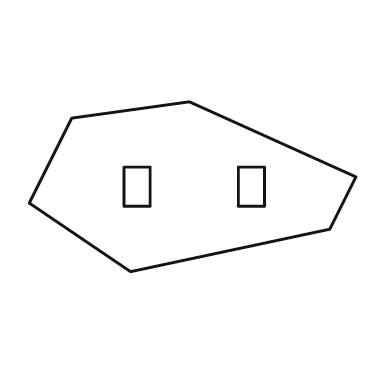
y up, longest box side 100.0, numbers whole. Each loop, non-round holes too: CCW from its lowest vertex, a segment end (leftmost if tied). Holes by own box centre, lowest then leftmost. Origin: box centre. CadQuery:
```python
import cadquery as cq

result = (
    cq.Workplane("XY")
    .moveTo(-19.0, -26.0)
    .lineTo(42.0, -13.0)
    .lineTo(50.0, 3.0)
    .lineTo(-1.0, 26.0)
    .lineTo(-37.0, 21.0)
    .lineTo(-50.0, -5.0)
    .close()
    .moveTo(-21.0, -6.0)
    .lineTo(-13.0, -6.0)
    .lineTo(-13.0, 6.0)
    .lineTo(-21.0, 6.0)
    .close()
    .moveTo(14.0, -6.0)
    .lineTo(22.0, -6.0)
    .lineTo(22.0, 6.0)
    .lineTo(14.0, 6.0)
    .close()
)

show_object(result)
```